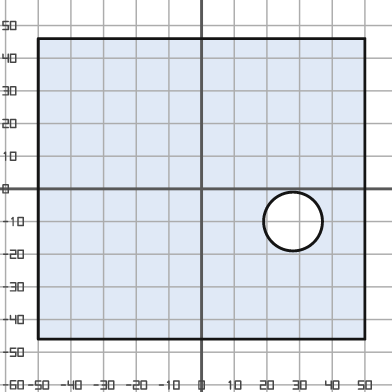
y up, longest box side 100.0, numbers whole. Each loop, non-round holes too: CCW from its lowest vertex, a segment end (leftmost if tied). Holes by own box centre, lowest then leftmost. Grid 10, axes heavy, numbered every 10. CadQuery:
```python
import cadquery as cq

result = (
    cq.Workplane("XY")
    .moveTo(-50.0, -46.0)
    .lineTo(50.0, -46.0)
    .lineTo(50.0, 46.0)
    .lineTo(-50.0, 46.0)
    .close()
    .moveTo(28.0, -10.0)
    .circle(9.0)
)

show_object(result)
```